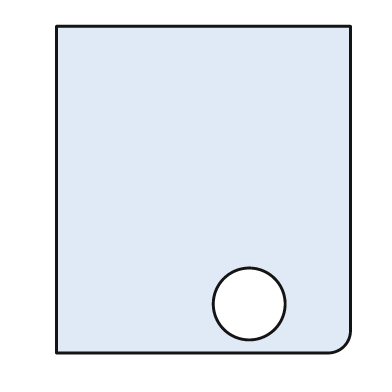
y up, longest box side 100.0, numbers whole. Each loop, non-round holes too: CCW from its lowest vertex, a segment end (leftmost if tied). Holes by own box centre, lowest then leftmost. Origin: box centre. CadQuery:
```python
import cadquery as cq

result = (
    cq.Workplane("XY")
    .moveTo(-45.0, -50.0)
    .lineTo(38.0, -50.0)
    .threePointArc((43.0, -48.0), (45.0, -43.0))
    .lineTo(45.0, 50.0)
    .lineTo(-45.0, 50.0)
    .close()
    .moveTo(14.0, -35.0)
    .circle(11.0)
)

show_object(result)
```